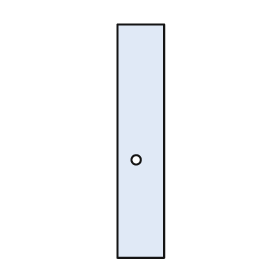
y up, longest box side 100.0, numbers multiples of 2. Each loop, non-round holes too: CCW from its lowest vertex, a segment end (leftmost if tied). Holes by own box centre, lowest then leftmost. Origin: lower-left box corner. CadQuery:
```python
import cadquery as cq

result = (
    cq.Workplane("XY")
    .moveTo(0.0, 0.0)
    .lineTo(20.0, 0.0)
    .lineTo(20.0, 100.0)
    .lineTo(0.0, 100.0)
    .close()
    .moveTo(8.0, 42.0)
    .circle(2.0)
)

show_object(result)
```